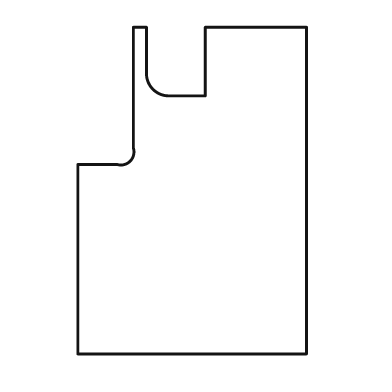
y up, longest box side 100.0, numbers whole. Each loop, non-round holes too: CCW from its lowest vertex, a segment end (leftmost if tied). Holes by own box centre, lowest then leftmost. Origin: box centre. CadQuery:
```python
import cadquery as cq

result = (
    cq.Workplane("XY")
    .moveTo(-35.0, -50.0)
    .lineTo(35.0, -50.0)
    .lineTo(35.0, 50.0)
    .lineTo(4.0, 50.0)
    .lineTo(4.0, 29.0)
    .lineTo(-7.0, 29.0)
    .threePointArc((-12.0, 31.0), (-14.0, 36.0))
    .lineTo(-14.0, 50.0)
    .lineTo(-18.0, 50.0)
    .lineTo(-18.0, 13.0)
    .threePointArc((-19.0, 9.0), (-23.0, 8.0))
    .lineTo(-35.0, 8.0)
    .close()
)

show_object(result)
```